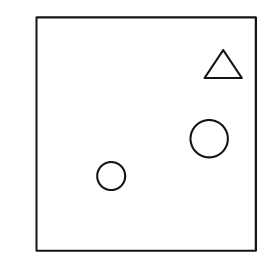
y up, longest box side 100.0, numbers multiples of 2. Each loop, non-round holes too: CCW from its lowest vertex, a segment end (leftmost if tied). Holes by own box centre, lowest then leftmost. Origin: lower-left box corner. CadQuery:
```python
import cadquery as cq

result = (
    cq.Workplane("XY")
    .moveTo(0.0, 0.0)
    .lineTo(94.0, 0.0)
    .lineTo(94.0, 100.0)
    .lineTo(0.0, 100.0)
    .close()
    .moveTo(32.0, 32.0)
    .circle(6.0)
    .moveTo(74.0, 48.0)
    .circle(8.0)
    .moveTo(72.0, 74.0)
    .lineTo(88.0, 74.0)
    .lineTo(80.0, 86.0)
    .close()
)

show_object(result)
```